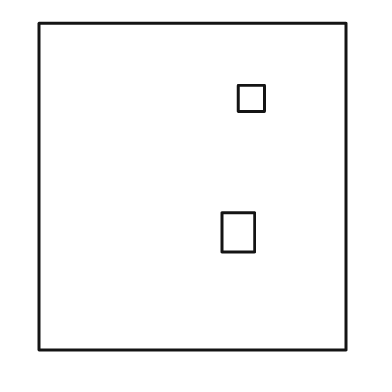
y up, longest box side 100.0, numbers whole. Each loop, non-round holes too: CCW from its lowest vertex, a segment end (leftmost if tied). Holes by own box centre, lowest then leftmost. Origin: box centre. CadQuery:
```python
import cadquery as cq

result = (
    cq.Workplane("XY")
    .moveTo(-47.0, -50.0)
    .lineTo(47.0, -50.0)
    .lineTo(47.0, 50.0)
    .lineTo(-47.0, 50.0)
    .close()
    .moveTo(9.0, -20.0)
    .lineTo(19.0, -20.0)
    .lineTo(19.0, -8.0)
    .lineTo(9.0, -8.0)
    .close()
    .moveTo(14.0, 23.0)
    .lineTo(22.0, 23.0)
    .lineTo(22.0, 31.0)
    .lineTo(14.0, 31.0)
    .close()
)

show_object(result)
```